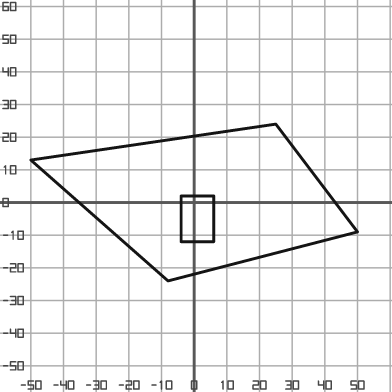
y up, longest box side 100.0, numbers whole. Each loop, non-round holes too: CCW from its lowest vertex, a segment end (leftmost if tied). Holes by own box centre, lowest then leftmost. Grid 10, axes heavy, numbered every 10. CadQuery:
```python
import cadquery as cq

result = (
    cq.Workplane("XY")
    .moveTo(-8.0, -24.0)
    .lineTo(50.0, -9.0)
    .lineTo(25.0, 24.0)
    .lineTo(-50.0, 13.0)
    .close()
    .moveTo(-4.0, -12.0)
    .lineTo(6.0, -12.0)
    .lineTo(6.0, 2.0)
    .lineTo(-4.0, 2.0)
    .close()
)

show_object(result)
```